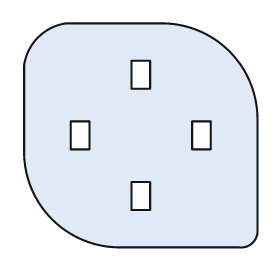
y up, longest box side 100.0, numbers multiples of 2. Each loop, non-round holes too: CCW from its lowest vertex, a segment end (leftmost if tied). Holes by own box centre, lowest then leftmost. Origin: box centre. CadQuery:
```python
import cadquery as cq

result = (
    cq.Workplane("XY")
    .moveTo(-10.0, -48.0)
    .lineTo(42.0, -48.0)
    .threePointArc((48.0, -46.0), (50.0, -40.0))
    .lineTo(50.0, 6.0)
    .threePointArc((38.0, 36.0), (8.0, 48.0))
    .lineTo(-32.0, 48.0)
    .threePointArc((-44.0, 42.0), (-50.0, 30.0))
    .lineTo(-50.0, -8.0)
    .threePointArc((-38.0, -36.0), (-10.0, -48.0))
    .close()
    .moveTo(-4.0, -32.0)
    .lineTo(4.0, -32.0)
    .lineTo(4.0, -20.0)
    .lineTo(-4.0, -20.0)
    .close()
    .moveTo(-30.0, -6.0)
    .lineTo(-22.0, -6.0)
    .lineTo(-22.0, 6.0)
    .lineTo(-30.0, 6.0)
    .close()
    .moveTo(22.0, -6.0)
    .lineTo(30.0, -6.0)
    .lineTo(30.0, 6.0)
    .lineTo(22.0, 6.0)
    .close()
    .moveTo(-4.0, 20.0)
    .lineTo(4.0, 20.0)
    .lineTo(4.0, 32.0)
    .lineTo(-4.0, 32.0)
    .close()
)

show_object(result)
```